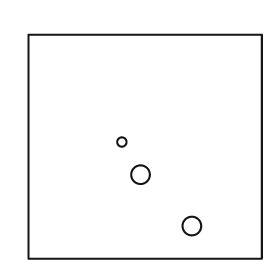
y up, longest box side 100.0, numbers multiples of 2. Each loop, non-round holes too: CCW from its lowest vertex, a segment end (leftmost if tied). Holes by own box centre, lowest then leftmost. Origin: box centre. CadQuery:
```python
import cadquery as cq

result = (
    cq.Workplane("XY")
    .moveTo(-50.0, -48.0)
    .lineTo(50.0, -48.0)
    .lineTo(50.0, 48.0)
    .lineTo(-50.0, 48.0)
    .close()
    .moveTo(20.0, -34.0)
    .circle(4.0)
    .moveTo(-2.0, -12.0)
    .circle(4.0)
    .moveTo(-10.0, 2.0)
    .circle(2.0)
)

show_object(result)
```